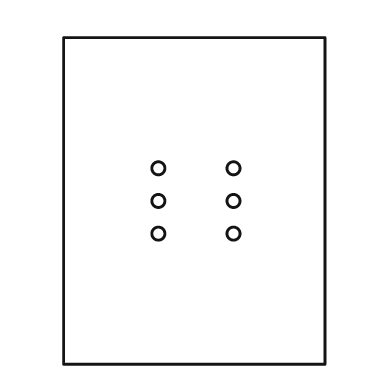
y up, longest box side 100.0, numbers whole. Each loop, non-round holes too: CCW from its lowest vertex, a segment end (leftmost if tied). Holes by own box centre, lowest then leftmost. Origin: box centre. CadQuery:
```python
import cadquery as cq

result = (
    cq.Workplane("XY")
    .moveTo(-40.0, -50.0)
    .lineTo(40.0, -50.0)
    .lineTo(40.0, 50.0)
    .lineTo(-40.0, 50.0)
    .close()
    .moveTo(-11.0, -10.0)
    .circle(2.0)
    .moveTo(12.0, -10.0)
    .circle(2.0)
    .moveTo(-11.0, 0.0)
    .circle(2.0)
    .moveTo(12.0, 0.0)
    .circle(2.0)
    .moveTo(-11.0, 10.0)
    .circle(2.0)
    .moveTo(12.0, 10.0)
    .circle(2.0)
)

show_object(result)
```